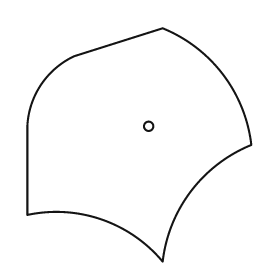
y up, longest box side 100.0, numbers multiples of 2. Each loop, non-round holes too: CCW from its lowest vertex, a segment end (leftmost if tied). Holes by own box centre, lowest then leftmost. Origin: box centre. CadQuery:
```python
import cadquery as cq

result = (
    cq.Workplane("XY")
    .moveTo(10.0, -50.0)
    .threePointArc((22.0, -20.0), (48.0, 0.0))
    .threePointArc((36.0, 30.0), (10.0, 50.0))
    .lineTo(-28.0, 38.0)
    .threePointArc((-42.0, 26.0), (-48.0, 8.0))
    .lineTo(-48.0, -30.0)
    .threePointArc((-16.0, -32.0), (10.0, -50.0))
    .close()
    .moveTo(4.0, 8.0)
    .circle(2.0)
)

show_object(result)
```